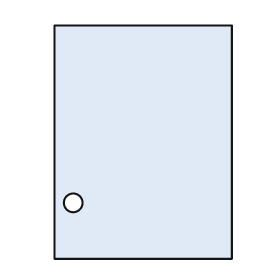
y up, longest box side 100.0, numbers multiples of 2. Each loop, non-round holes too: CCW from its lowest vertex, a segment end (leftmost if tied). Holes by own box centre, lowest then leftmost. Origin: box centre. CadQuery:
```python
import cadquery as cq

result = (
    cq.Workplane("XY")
    .moveTo(-38.0, -50.0)
    .lineTo(38.0, -50.0)
    .lineTo(38.0, 50.0)
    .lineTo(-38.0, 50.0)
    .close()
    .moveTo(-30.0, -26.0)
    .circle(4.0)
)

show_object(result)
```